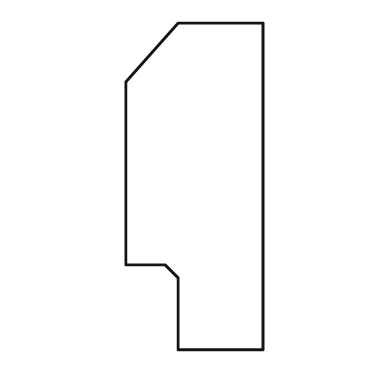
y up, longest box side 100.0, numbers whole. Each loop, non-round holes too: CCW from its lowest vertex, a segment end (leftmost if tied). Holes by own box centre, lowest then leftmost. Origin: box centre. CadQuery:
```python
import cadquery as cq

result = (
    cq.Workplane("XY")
    .moveTo(-5.0, -50.0)
    .lineTo(21.0, -50.0)
    .lineTo(21.0, 50.0)
    .lineTo(-5.0, 50.0)
    .lineTo(-21.0, 32.0)
    .lineTo(-21.0, -24.0)
    .lineTo(-9.0, -24.0)
    .lineTo(-5.0, -28.0)
    .close()
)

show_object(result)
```